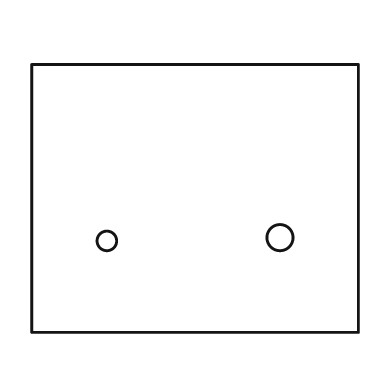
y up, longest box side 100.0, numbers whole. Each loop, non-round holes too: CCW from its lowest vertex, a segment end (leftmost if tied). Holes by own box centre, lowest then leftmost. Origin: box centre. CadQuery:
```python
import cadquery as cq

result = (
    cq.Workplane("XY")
    .moveTo(-50.0, -41.0)
    .lineTo(50.0, -41.0)
    .lineTo(50.0, 41.0)
    .lineTo(-50.0, 41.0)
    .close()
    .moveTo(-27.0, -13.0)
    .circle(3.0)
    .moveTo(26.0, -12.0)
    .circle(4.0)
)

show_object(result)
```